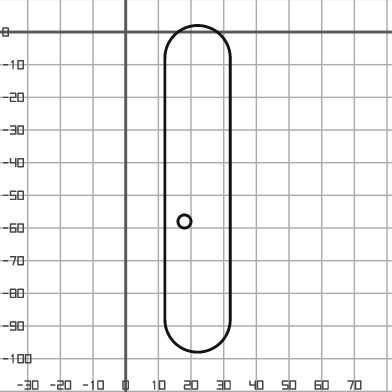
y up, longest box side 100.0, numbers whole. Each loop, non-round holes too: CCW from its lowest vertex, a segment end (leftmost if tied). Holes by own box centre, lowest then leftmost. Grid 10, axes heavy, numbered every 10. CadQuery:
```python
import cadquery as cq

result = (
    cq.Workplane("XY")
    .moveTo(12.0, -88.0)
    .threePointArc((22.0, -98.0), (32.0, -88.0))
    .lineTo(32.0, -8.0)
    .threePointArc((22.0, 2.0), (12.0, -8.0))
    .close()
    .moveTo(18.0, -58.0)
    .circle(2.0)
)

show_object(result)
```